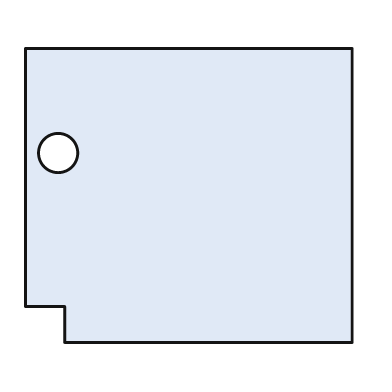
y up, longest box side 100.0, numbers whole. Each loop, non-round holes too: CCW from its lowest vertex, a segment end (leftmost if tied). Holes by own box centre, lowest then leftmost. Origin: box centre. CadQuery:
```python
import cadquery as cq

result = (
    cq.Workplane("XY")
    .moveTo(-38.0, -45.0)
    .lineTo(50.0, -45.0)
    .lineTo(50.0, 45.0)
    .lineTo(-50.0, 45.0)
    .lineTo(-50.0, -34.0)
    .lineTo(-38.0, -34.0)
    .close()
    .moveTo(-40.0, 13.0)
    .circle(6.0)
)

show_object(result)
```